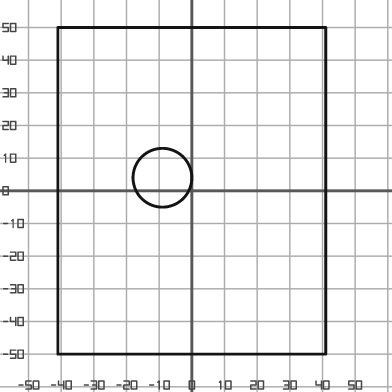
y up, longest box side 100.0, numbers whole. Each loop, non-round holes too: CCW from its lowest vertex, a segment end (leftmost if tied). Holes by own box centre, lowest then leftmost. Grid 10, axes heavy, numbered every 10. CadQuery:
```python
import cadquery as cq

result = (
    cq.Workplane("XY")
    .moveTo(-41.0, -50.0)
    .lineTo(41.0, -50.0)
    .lineTo(41.0, 50.0)
    .lineTo(-41.0, 50.0)
    .close()
    .moveTo(-9.0, 4.0)
    .circle(9.0)
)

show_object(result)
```